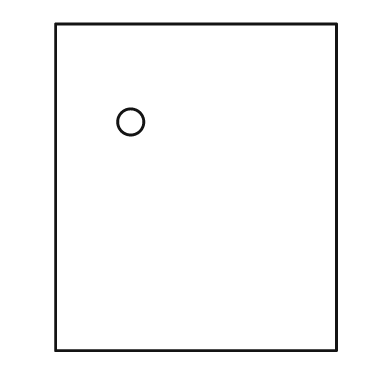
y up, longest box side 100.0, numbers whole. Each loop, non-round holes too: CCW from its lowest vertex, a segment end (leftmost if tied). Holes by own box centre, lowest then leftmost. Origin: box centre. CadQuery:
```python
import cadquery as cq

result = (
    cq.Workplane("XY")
    .moveTo(-43.0, -50.0)
    .lineTo(43.0, -50.0)
    .lineTo(43.0, 50.0)
    .lineTo(-43.0, 50.0)
    .close()
    .moveTo(-20.0, 20.0)
    .circle(4.0)
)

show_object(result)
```